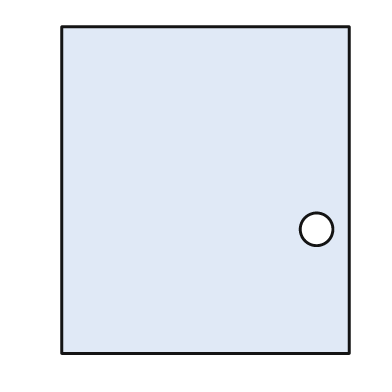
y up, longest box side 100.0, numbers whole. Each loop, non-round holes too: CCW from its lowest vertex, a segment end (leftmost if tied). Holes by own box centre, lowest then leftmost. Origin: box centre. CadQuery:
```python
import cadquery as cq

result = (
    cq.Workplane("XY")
    .moveTo(-44.0, -50.0)
    .lineTo(44.0, -50.0)
    .lineTo(44.0, 50.0)
    .lineTo(-44.0, 50.0)
    .close()
    .moveTo(34.0, -12.0)
    .circle(5.0)
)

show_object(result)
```